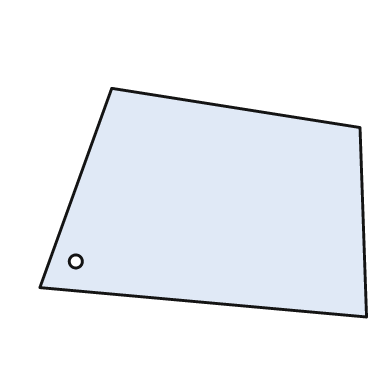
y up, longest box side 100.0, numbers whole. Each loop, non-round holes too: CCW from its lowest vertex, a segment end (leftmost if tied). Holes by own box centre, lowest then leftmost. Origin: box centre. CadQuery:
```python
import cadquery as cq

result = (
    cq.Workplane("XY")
    .moveTo(50.0, -35.0)
    .lineTo(48.0, 23.0)
    .lineTo(-28.0, 35.0)
    .lineTo(-50.0, -26.0)
    .close()
    .moveTo(-39.0, -18.0)
    .circle(2.0)
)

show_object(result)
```